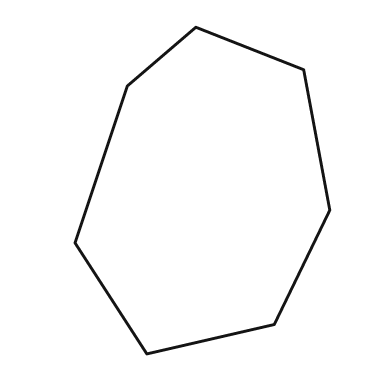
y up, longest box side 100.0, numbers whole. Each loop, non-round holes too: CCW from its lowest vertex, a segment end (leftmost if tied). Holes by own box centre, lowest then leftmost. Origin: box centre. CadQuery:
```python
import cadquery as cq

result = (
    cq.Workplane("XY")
    .moveTo(-17.0, -50.0)
    .lineTo(22.0, -41.0)
    .lineTo(39.0, -6.0)
    .lineTo(31.0, 37.0)
    .lineTo(-2.0, 50.0)
    .lineTo(-23.0, 32.0)
    .lineTo(-39.0, -16.0)
    .close()
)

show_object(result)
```